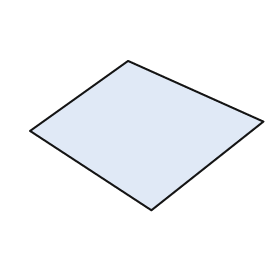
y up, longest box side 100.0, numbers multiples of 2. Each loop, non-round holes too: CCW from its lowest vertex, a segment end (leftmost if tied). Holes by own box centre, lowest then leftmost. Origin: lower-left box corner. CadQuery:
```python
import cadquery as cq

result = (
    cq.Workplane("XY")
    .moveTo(52.0, 0.0)
    .lineTo(100.0, 38.0)
    .lineTo(42.0, 64.0)
    .lineTo(0.0, 34.0)
    .close()
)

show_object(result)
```